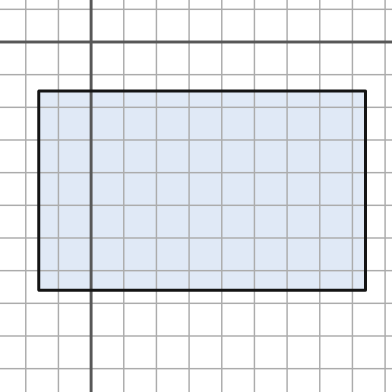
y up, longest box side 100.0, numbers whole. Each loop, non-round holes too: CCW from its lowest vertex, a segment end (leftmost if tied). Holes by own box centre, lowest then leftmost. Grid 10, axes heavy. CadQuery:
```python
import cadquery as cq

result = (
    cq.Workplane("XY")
    .moveTo(-16.0, -76.0)
    .lineTo(84.0, -76.0)
    .lineTo(84.0, -15.0)
    .lineTo(-16.0, -15.0)
    .close()
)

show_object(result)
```